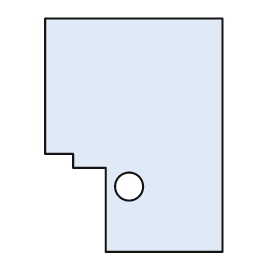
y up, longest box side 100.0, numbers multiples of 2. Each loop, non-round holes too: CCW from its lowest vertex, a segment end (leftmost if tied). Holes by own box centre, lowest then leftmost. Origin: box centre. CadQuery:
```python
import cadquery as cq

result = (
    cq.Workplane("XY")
    .moveTo(-12.0, -50.0)
    .lineTo(38.0, -50.0)
    .lineTo(38.0, 50.0)
    .lineTo(-38.0, 50.0)
    .lineTo(-38.0, -8.0)
    .lineTo(-26.0, -8.0)
    .lineTo(-26.0, -14.0)
    .lineTo(-12.0, -14.0)
    .close()
    .moveTo(-2.0, -22.0)
    .circle(6.0)
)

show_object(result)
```